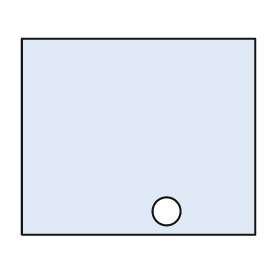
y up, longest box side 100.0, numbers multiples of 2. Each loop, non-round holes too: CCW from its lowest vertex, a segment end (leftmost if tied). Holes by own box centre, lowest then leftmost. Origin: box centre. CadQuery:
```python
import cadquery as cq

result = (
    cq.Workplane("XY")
    .moveTo(-50.0, -42.0)
    .lineTo(50.0, -42.0)
    .lineTo(50.0, 42.0)
    .lineTo(-50.0, 42.0)
    .close()
    .moveTo(12.0, -32.0)
    .circle(6.0)
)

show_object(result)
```